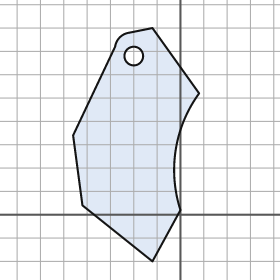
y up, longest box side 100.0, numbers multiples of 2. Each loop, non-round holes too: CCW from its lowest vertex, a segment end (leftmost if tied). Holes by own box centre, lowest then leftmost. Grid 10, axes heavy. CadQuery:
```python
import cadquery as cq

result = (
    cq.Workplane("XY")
    .moveTo(-12.0, -20.0)
    .lineTo(0.0, 2.0)
    .threePointArc((-2.0, 28.0), (8.0, 52.0))
    .lineTo(-12.0, 80.0)
    .lineTo(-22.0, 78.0)
    .threePointArc((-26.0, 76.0), (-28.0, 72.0))
    .lineTo(-46.0, 34.0)
    .lineTo(-42.0, 4.0)
    .close()
    .moveTo(-20.0, 68.0)
    .circle(4.0)
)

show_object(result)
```